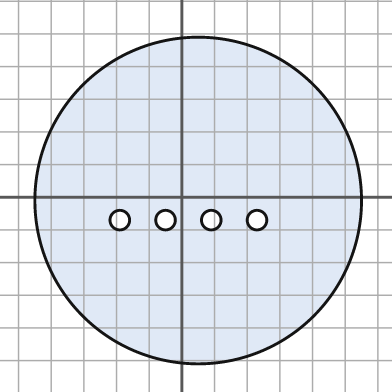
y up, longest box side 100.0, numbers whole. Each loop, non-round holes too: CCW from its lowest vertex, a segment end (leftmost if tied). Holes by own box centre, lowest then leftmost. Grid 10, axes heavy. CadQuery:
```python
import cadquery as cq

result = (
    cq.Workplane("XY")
    .moveTo(5.0, -1.0)
    .circle(50.0)
    .moveTo(-19.0, -7.0)
    .circle(3.0)
    .moveTo(-5.0, -7.0)
    .circle(3.0)
    .moveTo(9.0, -7.0)
    .circle(3.0)
    .moveTo(23.0, -7.0)
    .circle(3.0)
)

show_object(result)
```